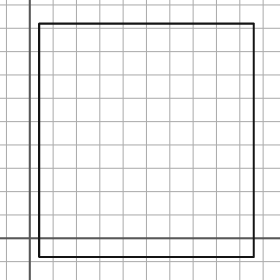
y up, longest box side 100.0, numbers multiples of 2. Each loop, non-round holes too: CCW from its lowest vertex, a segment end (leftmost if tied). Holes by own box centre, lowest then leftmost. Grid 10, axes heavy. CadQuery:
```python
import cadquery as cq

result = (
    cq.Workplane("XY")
    .moveTo(4.0, -8.0)
    .lineTo(96.0, -8.0)
    .lineTo(96.0, 92.0)
    .lineTo(4.0, 92.0)
    .close()
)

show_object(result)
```